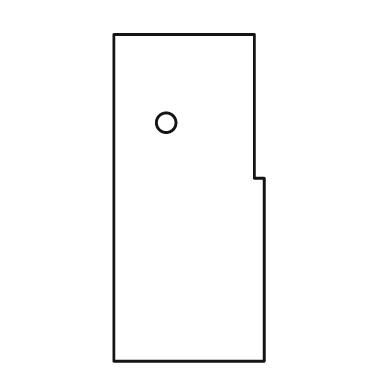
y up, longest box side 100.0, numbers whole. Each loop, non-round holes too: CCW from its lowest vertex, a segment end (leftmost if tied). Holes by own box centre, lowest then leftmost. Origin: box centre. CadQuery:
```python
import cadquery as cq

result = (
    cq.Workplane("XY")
    .moveTo(-23.0, -50.0)
    .lineTo(23.0, -50.0)
    .lineTo(23.0, 6.0)
    .lineTo(20.0, 6.0)
    .lineTo(20.0, 50.0)
    .lineTo(-23.0, 50.0)
    .close()
    .moveTo(-7.0, 23.0)
    .circle(3.0)
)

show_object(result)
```